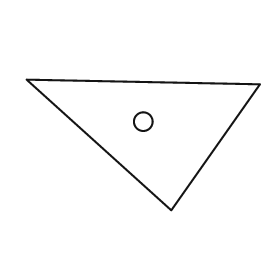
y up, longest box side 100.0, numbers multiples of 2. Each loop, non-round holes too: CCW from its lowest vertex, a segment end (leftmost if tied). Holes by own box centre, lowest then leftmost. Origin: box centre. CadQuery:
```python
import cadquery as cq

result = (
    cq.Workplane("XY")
    .moveTo(12.0, -28.0)
    .lineTo(50.0, 26.0)
    .lineTo(-50.0, 28.0)
    .close()
    .moveTo(0.0, 10.0)
    .circle(4.0)
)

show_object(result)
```